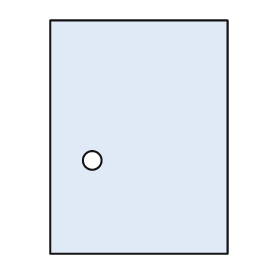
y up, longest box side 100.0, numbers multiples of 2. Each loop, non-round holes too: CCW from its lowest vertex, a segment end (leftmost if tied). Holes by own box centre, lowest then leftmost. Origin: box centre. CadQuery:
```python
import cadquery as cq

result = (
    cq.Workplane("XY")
    .moveTo(-38.0, -50.0)
    .lineTo(38.0, -50.0)
    .lineTo(38.0, 50.0)
    .lineTo(-38.0, 50.0)
    .close()
    .moveTo(-20.0, -10.0)
    .circle(4.0)
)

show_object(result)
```